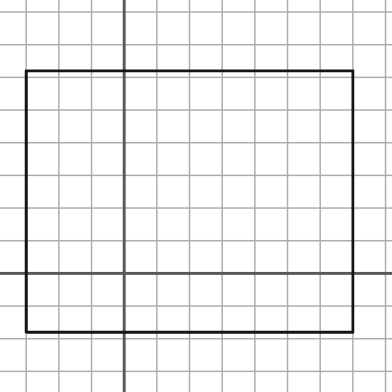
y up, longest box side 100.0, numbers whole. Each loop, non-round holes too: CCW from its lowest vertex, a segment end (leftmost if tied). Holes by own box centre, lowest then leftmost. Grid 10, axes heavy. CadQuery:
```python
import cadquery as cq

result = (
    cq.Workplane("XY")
    .moveTo(-30.0, -18.0)
    .lineTo(70.0, -18.0)
    .lineTo(70.0, 62.0)
    .lineTo(-30.0, 62.0)
    .close()
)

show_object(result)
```